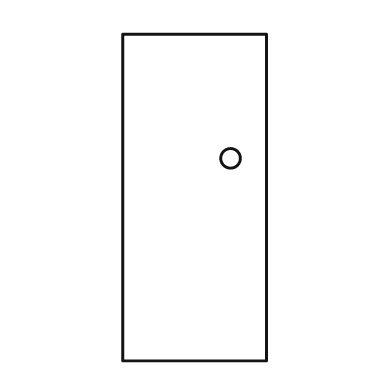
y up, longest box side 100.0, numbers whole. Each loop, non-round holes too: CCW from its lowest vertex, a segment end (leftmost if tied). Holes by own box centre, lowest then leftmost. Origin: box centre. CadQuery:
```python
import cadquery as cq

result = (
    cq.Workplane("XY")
    .moveTo(-22.0, -50.0)
    .lineTo(22.0, -50.0)
    .lineTo(22.0, 50.0)
    .lineTo(-22.0, 50.0)
    .close()
    .moveTo(11.0, 12.0)
    .circle(3.0)
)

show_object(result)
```